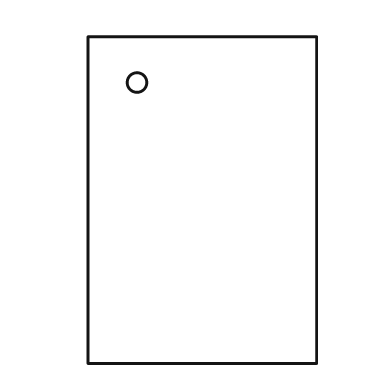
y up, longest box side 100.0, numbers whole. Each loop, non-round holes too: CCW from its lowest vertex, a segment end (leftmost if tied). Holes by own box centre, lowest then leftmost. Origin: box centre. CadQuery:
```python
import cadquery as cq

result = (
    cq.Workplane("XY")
    .moveTo(-35.0, -50.0)
    .lineTo(35.0, -50.0)
    .lineTo(35.0, 50.0)
    .lineTo(-35.0, 50.0)
    .close()
    .moveTo(-20.0, 36.0)
    .circle(3.0)
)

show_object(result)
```